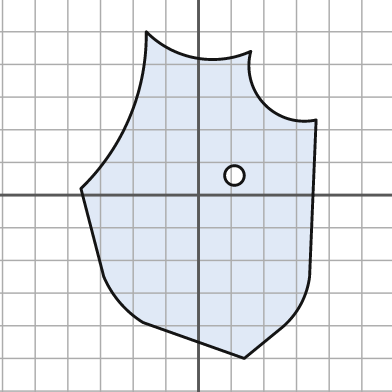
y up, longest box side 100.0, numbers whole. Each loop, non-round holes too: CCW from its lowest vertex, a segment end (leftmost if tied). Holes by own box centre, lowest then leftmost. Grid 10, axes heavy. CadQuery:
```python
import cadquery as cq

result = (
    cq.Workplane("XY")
    .moveTo(14.0, -50.0)
    .lineTo(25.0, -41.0)
    .threePointArc((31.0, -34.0), (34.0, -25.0))
    .lineTo(36.0, 23.0)
    .threePointArc((20.0, 28.0), (16.0, 44.0))
    .threePointArc((-1.0, 42.0), (-16.0, 50.0))
    .threePointArc((-21.0, 24.0), (-36.0, 2.0))
    .lineTo(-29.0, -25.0)
    .threePointArc((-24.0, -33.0), (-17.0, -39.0))
    .close()
    .moveTo(11.0, 6.0)
    .circle(3.0)
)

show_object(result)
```